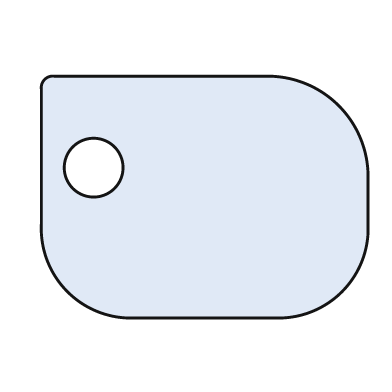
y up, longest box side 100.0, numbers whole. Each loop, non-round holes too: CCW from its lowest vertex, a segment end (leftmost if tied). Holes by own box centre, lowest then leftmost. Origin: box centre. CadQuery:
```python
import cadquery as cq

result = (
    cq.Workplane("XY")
    .moveTo(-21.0, -37.0)
    .lineTo(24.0, -37.0)
    .threePointArc((42.0, -29.0), (50.0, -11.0))
    .lineTo(50.0, 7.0)
    .threePointArc((41.0, 28.0), (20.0, 37.0))
    .lineTo(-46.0, 37.0)
    .threePointArc((-49.0, 36.0), (-50.0, 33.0))
    .lineTo(-50.0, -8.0)
    .threePointArc((-42.0, -29.0), (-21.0, -37.0))
    .close()
    .moveTo(-34.0, 9.0)
    .circle(9.0)
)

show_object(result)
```